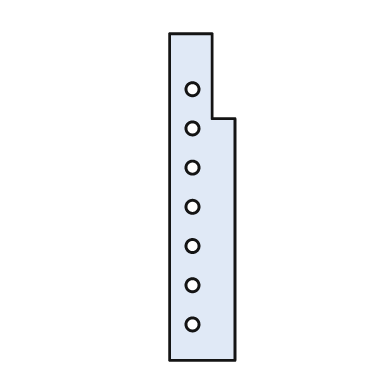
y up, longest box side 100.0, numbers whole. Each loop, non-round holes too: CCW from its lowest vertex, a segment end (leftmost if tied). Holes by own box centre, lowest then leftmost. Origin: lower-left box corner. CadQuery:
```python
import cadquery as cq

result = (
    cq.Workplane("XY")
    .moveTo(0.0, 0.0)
    .lineTo(20.0, 0.0)
    .lineTo(20.0, 74.0)
    .lineTo(13.0, 74.0)
    .lineTo(13.0, 100.0)
    .lineTo(0.0, 100.0)
    .close()
    .moveTo(7.0, 11.0)
    .circle(2.0)
    .moveTo(7.0, 23.0)
    .circle(2.0)
    .moveTo(7.0, 35.0)
    .circle(2.0)
    .moveTo(7.0, 47.0)
    .circle(2.0)
    .moveTo(7.0, 59.0)
    .circle(2.0)
    .moveTo(7.0, 71.0)
    .circle(2.0)
    .moveTo(7.0, 83.0)
    .circle(2.0)
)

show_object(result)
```